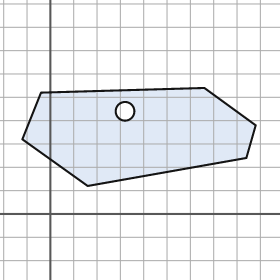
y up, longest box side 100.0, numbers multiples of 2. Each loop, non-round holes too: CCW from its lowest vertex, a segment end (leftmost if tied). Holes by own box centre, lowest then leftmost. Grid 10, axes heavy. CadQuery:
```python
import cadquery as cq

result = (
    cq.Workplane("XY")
    .moveTo(16.0, 12.0)
    .lineTo(84.0, 24.0)
    .lineTo(88.0, 38.0)
    .lineTo(66.0, 54.0)
    .lineTo(-4.0, 52.0)
    .lineTo(-12.0, 32.0)
    .close()
    .moveTo(32.0, 44.0)
    .circle(4.0)
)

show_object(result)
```